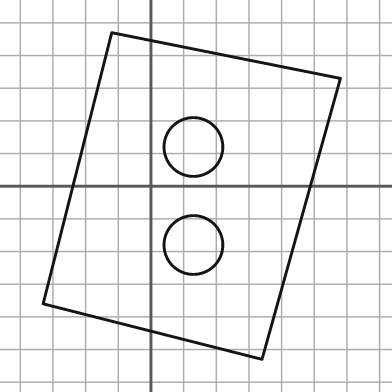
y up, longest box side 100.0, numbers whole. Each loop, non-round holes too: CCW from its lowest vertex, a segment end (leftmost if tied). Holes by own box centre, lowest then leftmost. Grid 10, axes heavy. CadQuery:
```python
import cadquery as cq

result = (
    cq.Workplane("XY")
    .moveTo(34.0, -53.0)
    .lineTo(58.0, 33.0)
    .lineTo(-12.0, 47.0)
    .lineTo(-33.0, -36.0)
    .close()
    .moveTo(13.0, -18.0)
    .circle(9.0)
    .moveTo(13.0, 12.0)
    .circle(9.0)
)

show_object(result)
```